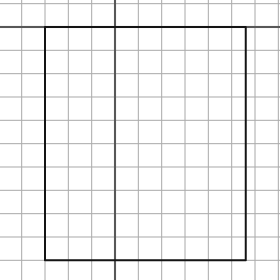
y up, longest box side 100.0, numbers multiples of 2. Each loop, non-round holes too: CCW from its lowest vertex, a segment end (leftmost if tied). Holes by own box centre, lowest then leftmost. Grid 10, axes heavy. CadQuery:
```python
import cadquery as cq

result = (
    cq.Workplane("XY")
    .moveTo(-30.0, -100.0)
    .lineTo(56.0, -100.0)
    .lineTo(56.0, 0.0)
    .lineTo(-30.0, 0.0)
    .close()
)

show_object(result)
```